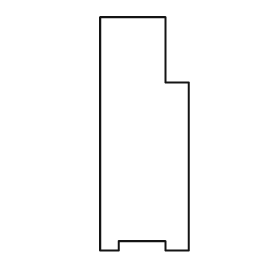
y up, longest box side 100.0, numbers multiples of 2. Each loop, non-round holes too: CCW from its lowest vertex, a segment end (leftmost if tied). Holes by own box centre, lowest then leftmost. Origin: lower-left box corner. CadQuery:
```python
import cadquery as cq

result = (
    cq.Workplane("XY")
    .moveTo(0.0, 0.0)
    .lineTo(8.0, 0.0)
    .lineTo(8.0, 4.0)
    .lineTo(28.0, 4.0)
    .lineTo(28.0, 0.0)
    .lineTo(38.0, 0.0)
    .lineTo(38.0, 72.0)
    .lineTo(28.0, 72.0)
    .lineTo(28.0, 100.0)
    .lineTo(0.0, 100.0)
    .close()
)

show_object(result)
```